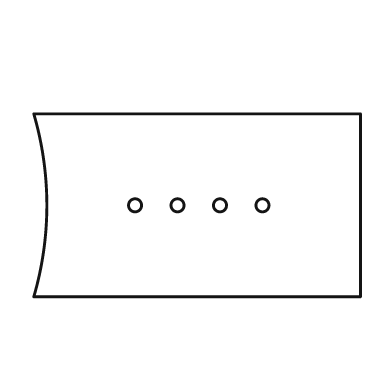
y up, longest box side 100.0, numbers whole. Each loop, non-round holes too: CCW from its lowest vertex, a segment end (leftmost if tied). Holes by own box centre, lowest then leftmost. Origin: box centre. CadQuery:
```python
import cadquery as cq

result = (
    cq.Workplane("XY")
    .moveTo(-50.0, -28.0)
    .lineTo(50.0, -28.0)
    .lineTo(50.0, 28.0)
    .lineTo(-50.0, 28.0)
    .threePointArc((-46.0, 0.0), (-50.0, -28.0))
    .close()
    .moveTo(-19.0, 0.0)
    .circle(2.0)
    .moveTo(-6.0, 0.0)
    .circle(2.0)
    .moveTo(7.0, 0.0)
    .circle(2.0)
    .moveTo(20.0, 0.0)
    .circle(2.0)
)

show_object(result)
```